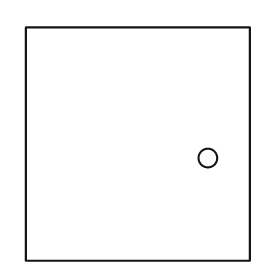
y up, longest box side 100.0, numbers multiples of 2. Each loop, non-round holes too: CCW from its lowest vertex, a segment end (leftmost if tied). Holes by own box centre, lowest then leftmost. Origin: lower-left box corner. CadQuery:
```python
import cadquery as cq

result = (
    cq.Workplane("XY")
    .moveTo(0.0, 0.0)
    .lineTo(96.0, 0.0)
    .lineTo(96.0, 100.0)
    .lineTo(0.0, 100.0)
    .close()
    .moveTo(78.0, 44.0)
    .circle(4.0)
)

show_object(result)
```